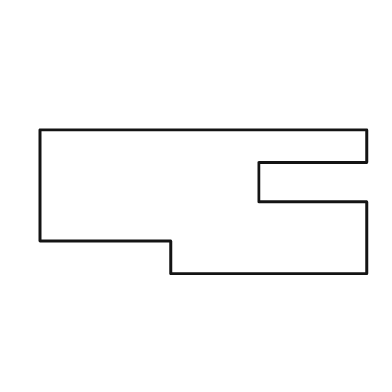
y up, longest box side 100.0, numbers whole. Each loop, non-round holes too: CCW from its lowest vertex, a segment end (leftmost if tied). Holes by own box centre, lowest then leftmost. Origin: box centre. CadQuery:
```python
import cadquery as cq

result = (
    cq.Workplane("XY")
    .moveTo(-10.0, -22.0)
    .lineTo(50.0, -22.0)
    .lineTo(50.0, 0.0)
    .lineTo(17.0, 0.0)
    .lineTo(17.0, 12.0)
    .lineTo(50.0, 12.0)
    .lineTo(50.0, 22.0)
    .lineTo(-50.0, 22.0)
    .lineTo(-50.0, -12.0)
    .lineTo(-10.0, -12.0)
    .close()
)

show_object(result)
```